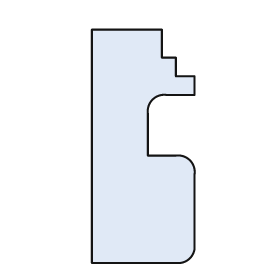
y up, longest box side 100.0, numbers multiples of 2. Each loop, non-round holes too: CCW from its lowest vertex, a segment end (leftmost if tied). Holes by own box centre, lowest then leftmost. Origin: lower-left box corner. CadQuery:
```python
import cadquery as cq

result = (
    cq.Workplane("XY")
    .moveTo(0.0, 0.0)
    .lineTo(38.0, 0.0)
    .threePointArc((42.0, 2.0), (44.0, 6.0))
    .lineTo(44.0, 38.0)
    .threePointArc((42.0, 44.0), (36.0, 46.0))
    .lineTo(24.0, 46.0)
    .lineTo(24.0, 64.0)
    .threePointArc((26.0, 70.0), (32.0, 72.0))
    .lineTo(44.0, 72.0)
    .lineTo(44.0, 80.0)
    .lineTo(36.0, 80.0)
    .lineTo(36.0, 88.0)
    .lineTo(30.0, 88.0)
    .lineTo(30.0, 100.0)
    .lineTo(0.0, 100.0)
    .close()
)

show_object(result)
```